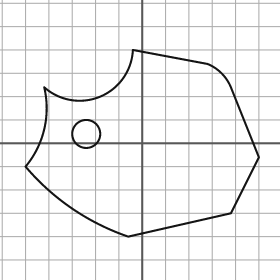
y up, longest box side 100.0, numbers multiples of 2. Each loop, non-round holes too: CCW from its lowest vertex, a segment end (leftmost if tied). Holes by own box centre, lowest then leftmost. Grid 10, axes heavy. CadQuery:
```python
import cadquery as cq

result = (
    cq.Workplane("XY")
    .moveTo(-6.0, -40.0)
    .lineTo(38.0, -30.0)
    .lineTo(50.0, -6.0)
    .lineTo(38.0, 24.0)
    .threePointArc((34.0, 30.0), (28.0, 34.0))
    .lineTo(-4.0, 40.0)
    .threePointArc((-18.0, 20.0), (-42.0, 24.0))
    .threePointArc((-42.0, 6.0), (-50.0, -10.0))
    .threePointArc((-30.0, -28.0), (-6.0, -40.0))
    .close()
    .moveTo(-24.0, 4.0)
    .circle(6.0)
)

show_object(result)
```